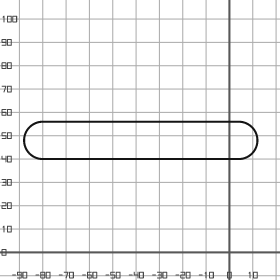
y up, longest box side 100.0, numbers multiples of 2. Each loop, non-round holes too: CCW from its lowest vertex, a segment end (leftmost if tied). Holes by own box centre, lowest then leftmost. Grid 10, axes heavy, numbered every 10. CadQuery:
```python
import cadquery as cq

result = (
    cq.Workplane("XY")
    .moveTo(-80.0, 40.0)
    .lineTo(4.0, 40.0)
    .threePointArc((12.0, 48.0), (4.0, 56.0))
    .lineTo(-80.0, 56.0)
    .threePointArc((-88.0, 48.0), (-80.0, 40.0))
    .close()
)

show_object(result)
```